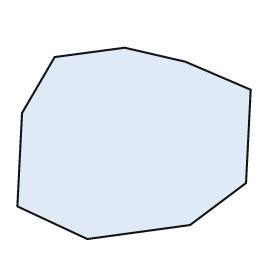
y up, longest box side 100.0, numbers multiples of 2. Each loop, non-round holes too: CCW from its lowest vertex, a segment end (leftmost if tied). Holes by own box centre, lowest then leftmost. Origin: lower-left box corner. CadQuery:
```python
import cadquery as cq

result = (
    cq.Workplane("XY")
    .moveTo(30.0, 0.0)
    .lineTo(74.0, 6.0)
    .lineTo(98.0, 24.0)
    .lineTo(100.0, 64.0)
    .lineTo(72.0, 76.0)
    .lineTo(46.0, 82.0)
    .lineTo(16.0, 78.0)
    .lineTo(2.0, 54.0)
    .lineTo(0.0, 14.0)
    .close()
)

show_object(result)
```